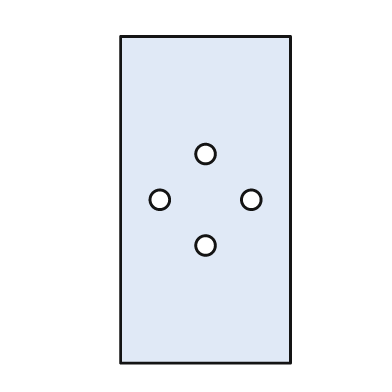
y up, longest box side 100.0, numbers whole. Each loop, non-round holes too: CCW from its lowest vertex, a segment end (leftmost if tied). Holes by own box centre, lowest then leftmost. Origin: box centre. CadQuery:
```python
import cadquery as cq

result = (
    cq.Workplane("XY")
    .moveTo(-26.0, -50.0)
    .lineTo(26.0, -50.0)
    .lineTo(26.0, 50.0)
    .lineTo(-26.0, 50.0)
    .close()
    .moveTo(0.0, -14.0)
    .circle(3.0)
    .moveTo(-14.0, 0.0)
    .circle(3.0)
    .moveTo(14.0, 0.0)
    .circle(3.0)
    .moveTo(0.0, 14.0)
    .circle(3.0)
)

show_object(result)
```